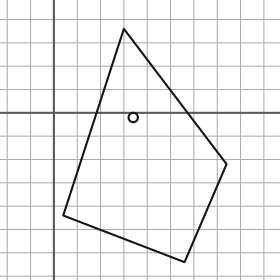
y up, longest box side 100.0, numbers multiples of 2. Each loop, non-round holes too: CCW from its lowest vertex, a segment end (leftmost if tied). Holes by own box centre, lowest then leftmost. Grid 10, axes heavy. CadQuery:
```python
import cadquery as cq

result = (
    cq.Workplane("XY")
    .moveTo(56.0, -64.0)
    .lineTo(74.0, -22.0)
    .lineTo(30.0, 36.0)
    .lineTo(4.0, -44.0)
    .close()
    .moveTo(34.0, -2.0)
    .circle(2.0)
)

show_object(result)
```